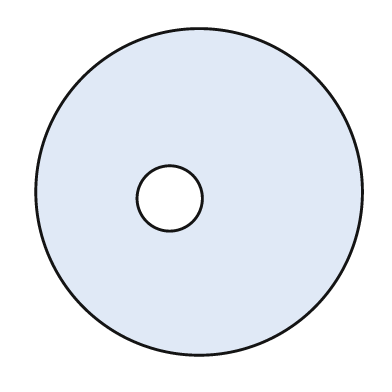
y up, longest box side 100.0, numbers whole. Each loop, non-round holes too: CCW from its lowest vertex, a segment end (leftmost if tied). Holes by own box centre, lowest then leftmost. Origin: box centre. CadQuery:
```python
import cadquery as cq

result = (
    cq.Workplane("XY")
    .moveTo(0.0, 0.0)
    .circle(50.0)
    .moveTo(-9.0, -2.0)
    .circle(10.0)
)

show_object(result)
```